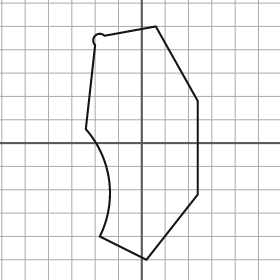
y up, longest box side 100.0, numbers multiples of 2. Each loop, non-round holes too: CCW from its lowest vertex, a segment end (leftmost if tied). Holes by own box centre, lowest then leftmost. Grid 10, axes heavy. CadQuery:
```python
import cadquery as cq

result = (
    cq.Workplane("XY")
    .moveTo(2.0, -50.0)
    .lineTo(24.0, -22.0)
    .lineTo(24.0, 18.0)
    .lineTo(6.0, 50.0)
    .lineTo(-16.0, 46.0)
    .threePointArc((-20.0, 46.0), (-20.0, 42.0))
    .lineTo(-24.0, 6.0)
    .threePointArc((-14.0, -16.0), (-18.0, -40.0))
    .close()
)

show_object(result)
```